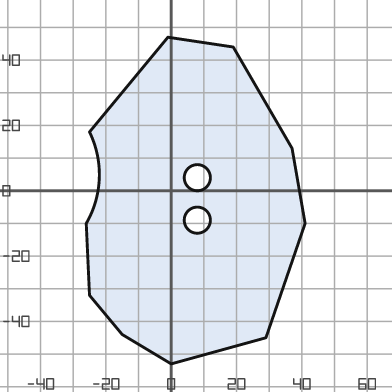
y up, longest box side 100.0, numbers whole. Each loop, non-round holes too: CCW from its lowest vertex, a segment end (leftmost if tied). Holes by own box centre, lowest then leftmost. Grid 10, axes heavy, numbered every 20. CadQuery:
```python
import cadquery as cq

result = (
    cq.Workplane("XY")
    .moveTo(0.0, -53.0)
    .lineTo(29.0, -45.0)
    .lineTo(41.0, -10.0)
    .lineTo(37.0, 13.0)
    .lineTo(19.0, 44.0)
    .lineTo(-1.0, 47.0)
    .lineTo(-25.0, 18.0)
    .threePointArc((-22.0, 4.0), (-26.0, -10.0))
    .lineTo(-25.0, -32.0)
    .lineTo(-15.0, -44.0)
    .close()
    .moveTo(8.0, -9.0)
    .circle(4.0)
    .moveTo(8.0, 4.0)
    .circle(4.0)
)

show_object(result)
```